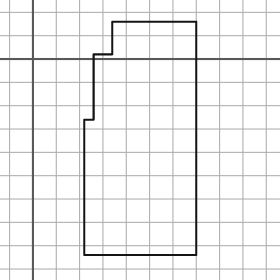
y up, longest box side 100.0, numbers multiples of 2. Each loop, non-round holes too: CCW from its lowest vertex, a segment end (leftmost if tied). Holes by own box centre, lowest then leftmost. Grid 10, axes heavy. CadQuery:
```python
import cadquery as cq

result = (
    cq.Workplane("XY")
    .moveTo(22.0, -84.0)
    .lineTo(70.0, -84.0)
    .lineTo(70.0, 16.0)
    .lineTo(34.0, 16.0)
    .lineTo(34.0, 2.0)
    .lineTo(26.0, 2.0)
    .lineTo(26.0, -26.0)
    .lineTo(22.0, -26.0)
    .close()
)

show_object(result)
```